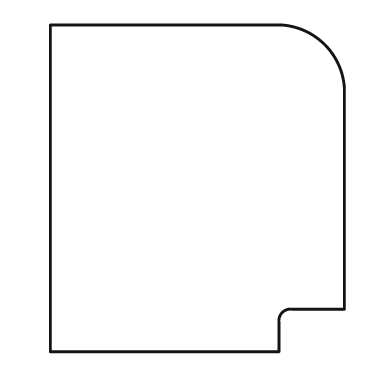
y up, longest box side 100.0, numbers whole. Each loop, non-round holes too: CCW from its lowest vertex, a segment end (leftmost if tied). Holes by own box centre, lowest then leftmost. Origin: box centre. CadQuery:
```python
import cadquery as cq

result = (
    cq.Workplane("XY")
    .moveTo(-45.0, -50.0)
    .lineTo(25.0, -50.0)
    .lineTo(25.0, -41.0)
    .threePointArc((26.0, -38.0), (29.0, -37.0))
    .lineTo(45.0, -37.0)
    .lineTo(45.0, 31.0)
    .threePointArc((39.0, 44.0), (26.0, 50.0))
    .lineTo(-45.0, 50.0)
    .close()
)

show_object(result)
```